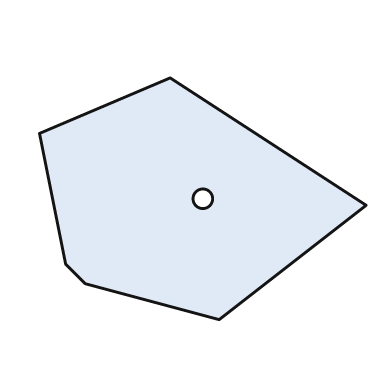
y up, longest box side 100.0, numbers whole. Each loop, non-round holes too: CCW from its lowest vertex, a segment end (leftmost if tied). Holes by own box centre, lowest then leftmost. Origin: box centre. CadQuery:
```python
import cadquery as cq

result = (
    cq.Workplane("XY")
    .moveTo(5.0, -37.0)
    .lineTo(50.0, -2.0)
    .lineTo(-10.0, 37.0)
    .lineTo(-50.0, 20.0)
    .lineTo(-42.0, -20.0)
    .lineTo(-36.0, -26.0)
    .close()
    .moveTo(0.0, 0.0)
    .circle(3.0)
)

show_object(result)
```